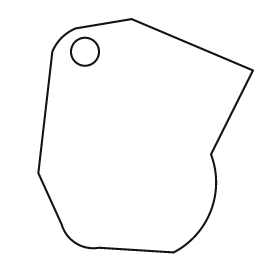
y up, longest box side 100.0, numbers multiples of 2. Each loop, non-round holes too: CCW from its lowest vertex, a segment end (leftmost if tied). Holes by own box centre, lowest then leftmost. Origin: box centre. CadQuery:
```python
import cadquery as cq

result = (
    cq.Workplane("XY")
    .moveTo(12.0, -50.0)
    .threePointArc((28.0, -32.0), (28.0, -8.0))
    .lineTo(46.0, 28.0)
    .lineTo(-6.0, 50.0)
    .lineTo(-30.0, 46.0)
    .threePointArc((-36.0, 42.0), (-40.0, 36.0))
    .lineTo(-46.0, -16.0)
    .lineTo(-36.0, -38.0)
    .threePointArc((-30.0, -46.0), (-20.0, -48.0))
    .close()
    .moveTo(-26.0, 36.0)
    .circle(6.0)
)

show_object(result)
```